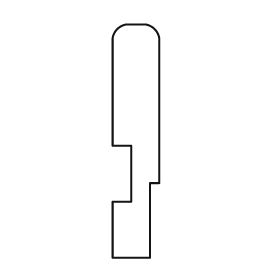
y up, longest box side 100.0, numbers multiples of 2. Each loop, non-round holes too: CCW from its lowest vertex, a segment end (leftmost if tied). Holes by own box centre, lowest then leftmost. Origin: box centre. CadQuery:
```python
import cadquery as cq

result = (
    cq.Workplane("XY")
    .moveTo(-10.0, -50.0)
    .lineTo(6.0, -50.0)
    .lineTo(6.0, -18.0)
    .lineTo(10.0, -18.0)
    .lineTo(10.0, 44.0)
    .threePointArc((8.0, 48.0), (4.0, 50.0))
    .lineTo(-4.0, 50.0)
    .threePointArc((-8.0, 48.0), (-10.0, 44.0))
    .lineTo(-10.0, -2.0)
    .lineTo(-2.0, -2.0)
    .lineTo(-2.0, -26.0)
    .lineTo(-10.0, -26.0)
    .close()
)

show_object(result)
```